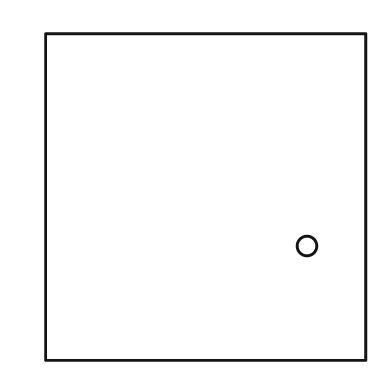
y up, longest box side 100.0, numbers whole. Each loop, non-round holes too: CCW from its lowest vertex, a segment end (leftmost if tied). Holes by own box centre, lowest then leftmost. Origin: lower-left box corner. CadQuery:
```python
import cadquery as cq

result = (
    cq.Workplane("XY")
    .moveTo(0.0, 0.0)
    .lineTo(98.0, 0.0)
    .lineTo(98.0, 100.0)
    .lineTo(0.0, 100.0)
    .close()
    .moveTo(80.0, 35.0)
    .circle(3.0)
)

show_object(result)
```